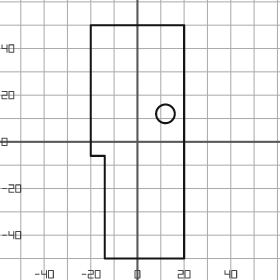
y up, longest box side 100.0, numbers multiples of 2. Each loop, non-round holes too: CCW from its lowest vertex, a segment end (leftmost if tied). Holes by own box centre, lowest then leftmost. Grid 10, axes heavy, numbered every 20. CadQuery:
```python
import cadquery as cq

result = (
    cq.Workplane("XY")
    .moveTo(-14.0, -50.0)
    .lineTo(20.0, -50.0)
    .lineTo(20.0, 50.0)
    .lineTo(-20.0, 50.0)
    .lineTo(-20.0, -6.0)
    .lineTo(-14.0, -6.0)
    .close()
    .moveTo(12.0, 12.0)
    .circle(4.0)
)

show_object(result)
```